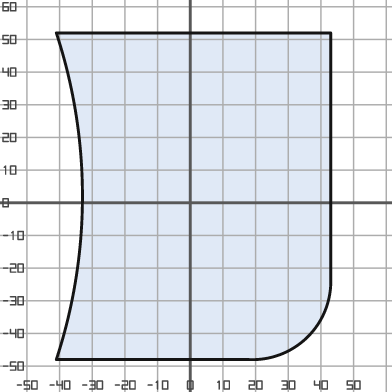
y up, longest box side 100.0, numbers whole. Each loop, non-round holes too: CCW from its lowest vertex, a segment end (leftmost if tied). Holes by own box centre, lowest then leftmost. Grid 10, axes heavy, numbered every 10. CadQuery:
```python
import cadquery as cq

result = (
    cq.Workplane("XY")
    .moveTo(-41.0, -48.0)
    .lineTo(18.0, -48.0)
    .threePointArc((36.0, -41.0), (43.0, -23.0))
    .lineTo(43.0, 52.0)
    .lineTo(-41.0, 52.0)
    .threePointArc((-33.0, 2.0), (-41.0, -48.0))
    .close()
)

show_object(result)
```